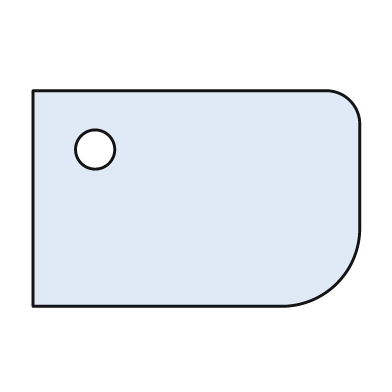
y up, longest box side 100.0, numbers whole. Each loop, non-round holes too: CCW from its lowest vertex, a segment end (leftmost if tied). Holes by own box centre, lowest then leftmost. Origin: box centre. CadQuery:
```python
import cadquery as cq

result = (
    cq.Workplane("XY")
    .moveTo(-50.0, -33.0)
    .lineTo(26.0, -33.0)
    .threePointArc((43.0, -26.0), (50.0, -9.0))
    .lineTo(50.0, 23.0)
    .threePointArc((47.0, 30.0), (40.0, 33.0))
    .lineTo(-50.0, 33.0)
    .close()
    .moveTo(-31.0, 15.0)
    .circle(6.0)
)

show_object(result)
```